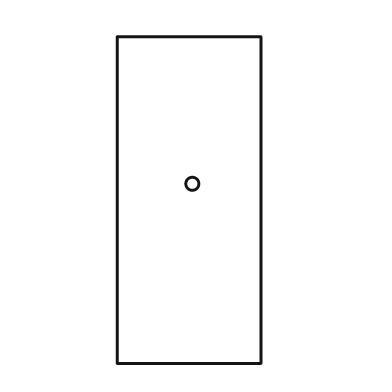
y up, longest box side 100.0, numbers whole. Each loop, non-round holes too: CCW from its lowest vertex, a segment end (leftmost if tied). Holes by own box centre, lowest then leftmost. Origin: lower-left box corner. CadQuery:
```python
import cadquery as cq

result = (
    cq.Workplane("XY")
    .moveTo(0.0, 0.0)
    .lineTo(44.0, 0.0)
    .lineTo(44.0, 100.0)
    .lineTo(0.0, 100.0)
    .close()
    .moveTo(23.0, 55.0)
    .circle(2.0)
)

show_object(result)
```